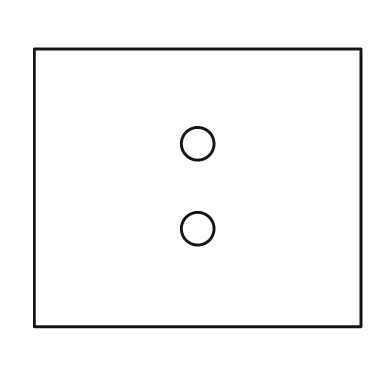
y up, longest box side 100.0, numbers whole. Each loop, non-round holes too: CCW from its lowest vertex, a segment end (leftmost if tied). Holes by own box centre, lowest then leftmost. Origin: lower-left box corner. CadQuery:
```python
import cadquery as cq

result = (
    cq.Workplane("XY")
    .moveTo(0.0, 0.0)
    .lineTo(100.0, 0.0)
    .lineTo(100.0, 85.0)
    .lineTo(0.0, 85.0)
    .close()
    .moveTo(50.0, 30.0)
    .circle(5.0)
    .moveTo(50.0, 56.0)
    .circle(5.0)
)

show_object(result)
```